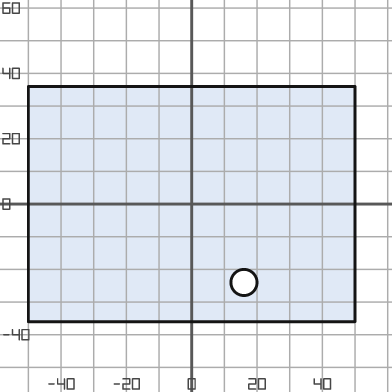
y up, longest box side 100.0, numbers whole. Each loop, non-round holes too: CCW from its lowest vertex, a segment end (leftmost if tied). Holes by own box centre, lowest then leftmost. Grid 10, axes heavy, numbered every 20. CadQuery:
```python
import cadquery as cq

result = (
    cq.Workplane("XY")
    .moveTo(-50.0, -36.0)
    .lineTo(50.0, -36.0)
    .lineTo(50.0, 36.0)
    .lineTo(-50.0, 36.0)
    .close()
    .moveTo(16.0, -24.0)
    .circle(4.0)
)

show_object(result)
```